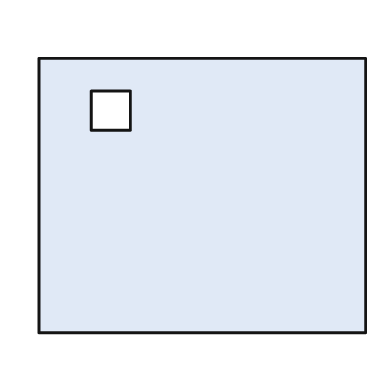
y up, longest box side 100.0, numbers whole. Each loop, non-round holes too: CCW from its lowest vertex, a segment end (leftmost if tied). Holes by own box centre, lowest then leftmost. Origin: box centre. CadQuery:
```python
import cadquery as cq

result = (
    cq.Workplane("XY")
    .moveTo(-50.0, -42.0)
    .lineTo(50.0, -42.0)
    .lineTo(50.0, 42.0)
    .lineTo(-50.0, 42.0)
    .close()
    .moveTo(-34.0, 20.0)
    .lineTo(-22.0, 20.0)
    .lineTo(-22.0, 32.0)
    .lineTo(-34.0, 32.0)
    .close()
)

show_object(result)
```